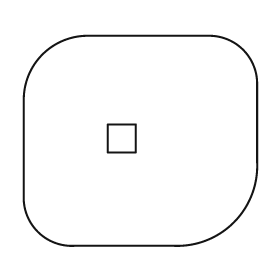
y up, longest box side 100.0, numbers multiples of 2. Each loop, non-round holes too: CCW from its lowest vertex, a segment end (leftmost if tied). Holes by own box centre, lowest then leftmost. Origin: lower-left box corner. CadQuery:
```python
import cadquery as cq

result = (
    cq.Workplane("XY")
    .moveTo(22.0, 0.0)
    .lineTo(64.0, 0.0)
    .threePointArc((90.0, 10.0), (100.0, 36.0))
    .lineTo(100.0, 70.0)
    .threePointArc((94.0, 84.0), (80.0, 90.0))
    .lineTo(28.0, 90.0)
    .threePointArc((8.0, 82.0), (0.0, 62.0))
    .lineTo(0.0, 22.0)
    .threePointArc((6.0, 6.0), (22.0, 0.0))
    .close()
    .moveTo(36.0, 40.0)
    .lineTo(48.0, 40.0)
    .lineTo(48.0, 52.0)
    .lineTo(36.0, 52.0)
    .close()
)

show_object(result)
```